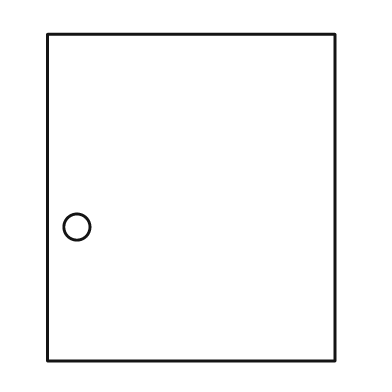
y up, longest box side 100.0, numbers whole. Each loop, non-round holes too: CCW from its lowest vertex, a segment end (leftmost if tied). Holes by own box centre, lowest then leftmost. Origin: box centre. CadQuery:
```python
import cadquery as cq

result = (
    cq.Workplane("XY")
    .moveTo(-44.0, -50.0)
    .lineTo(44.0, -50.0)
    .lineTo(44.0, 50.0)
    .lineTo(-44.0, 50.0)
    .close()
    .moveTo(-35.0, -9.0)
    .circle(4.0)
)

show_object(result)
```